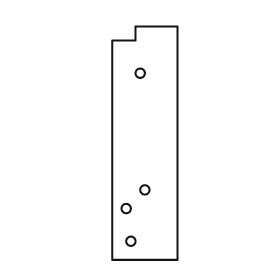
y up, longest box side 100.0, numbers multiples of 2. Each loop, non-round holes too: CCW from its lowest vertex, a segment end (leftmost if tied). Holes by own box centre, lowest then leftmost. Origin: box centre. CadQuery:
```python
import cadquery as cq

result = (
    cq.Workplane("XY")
    .moveTo(-14.0, -50.0)
    .lineTo(14.0, -50.0)
    .lineTo(14.0, 50.0)
    .lineTo(-4.0, 50.0)
    .lineTo(-4.0, 44.0)
    .lineTo(-14.0, 44.0)
    .close()
    .moveTo(-6.0, -42.0)
    .circle(2.0)
    .moveTo(-8.0, -28.0)
    .circle(2.0)
    .moveTo(0.0, -20.0)
    .circle(2.0)
    .moveTo(-2.0, 30.0)
    .circle(2.0)
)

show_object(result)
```